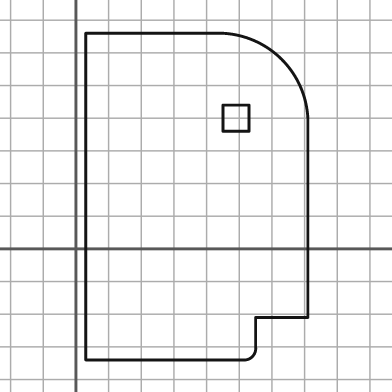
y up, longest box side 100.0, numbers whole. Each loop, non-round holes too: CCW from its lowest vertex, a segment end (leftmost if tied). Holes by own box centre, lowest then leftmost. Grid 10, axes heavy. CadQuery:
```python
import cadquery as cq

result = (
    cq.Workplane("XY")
    .moveTo(3.0, -34.0)
    .lineTo(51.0, -34.0)
    .threePointArc((54.0, -33.0), (55.0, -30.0))
    .lineTo(55.0, -21.0)
    .lineTo(71.0, -21.0)
    .lineTo(71.0, 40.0)
    .threePointArc((63.0, 58.0), (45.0, 66.0))
    .lineTo(3.0, 66.0)
    .close()
    .moveTo(45.0, 36.0)
    .lineTo(53.0, 36.0)
    .lineTo(53.0, 44.0)
    .lineTo(45.0, 44.0)
    .close()
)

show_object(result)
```